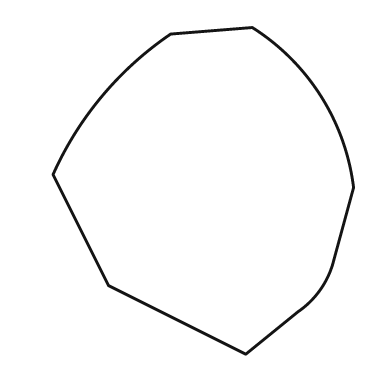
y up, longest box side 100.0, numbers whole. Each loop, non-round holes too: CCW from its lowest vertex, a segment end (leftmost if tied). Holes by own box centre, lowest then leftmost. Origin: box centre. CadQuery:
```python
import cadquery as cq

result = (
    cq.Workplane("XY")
    .moveTo(13.0, -50.0)
    .lineTo(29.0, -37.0)
    .threePointArc((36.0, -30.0), (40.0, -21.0))
    .lineTo(46.0, 1.0)
    .threePointArc((36.0, 29.0), (15.0, 50.0))
    .lineTo(-10.0, 48.0)
    .threePointArc((-31.0, 29.0), (-46.0, 5.0))
    .lineTo(-29.0, -29.0)
    .close()
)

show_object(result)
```